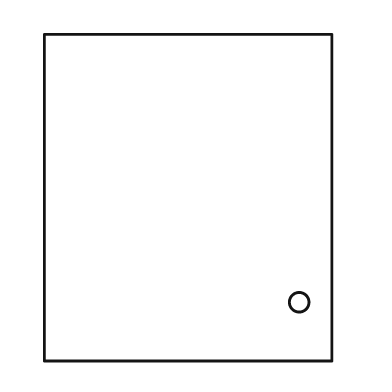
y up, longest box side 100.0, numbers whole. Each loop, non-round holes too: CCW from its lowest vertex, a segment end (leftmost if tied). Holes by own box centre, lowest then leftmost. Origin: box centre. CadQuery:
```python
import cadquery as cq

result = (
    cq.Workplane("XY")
    .moveTo(-44.0, -50.0)
    .lineTo(44.0, -50.0)
    .lineTo(44.0, 50.0)
    .lineTo(-44.0, 50.0)
    .close()
    .moveTo(34.0, -32.0)
    .circle(3.0)
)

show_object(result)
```